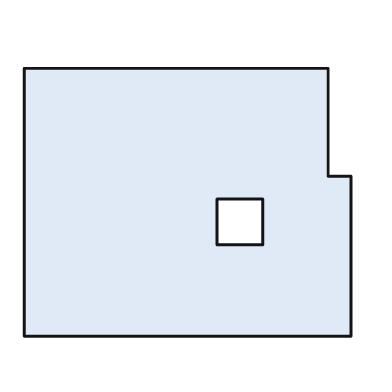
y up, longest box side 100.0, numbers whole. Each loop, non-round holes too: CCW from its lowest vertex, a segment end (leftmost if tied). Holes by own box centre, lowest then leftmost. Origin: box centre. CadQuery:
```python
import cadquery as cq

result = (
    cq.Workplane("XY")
    .moveTo(-50.0, -41.0)
    .lineTo(50.0, -41.0)
    .lineTo(50.0, 8.0)
    .lineTo(43.0, 8.0)
    .lineTo(43.0, 41.0)
    .lineTo(-50.0, 41.0)
    .close()
    .moveTo(9.0, -13.0)
    .lineTo(23.0, -13.0)
    .lineTo(23.0, 1.0)
    .lineTo(9.0, 1.0)
    .close()
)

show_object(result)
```